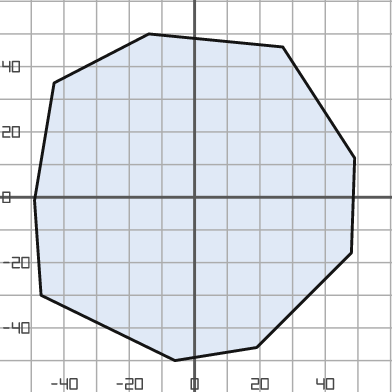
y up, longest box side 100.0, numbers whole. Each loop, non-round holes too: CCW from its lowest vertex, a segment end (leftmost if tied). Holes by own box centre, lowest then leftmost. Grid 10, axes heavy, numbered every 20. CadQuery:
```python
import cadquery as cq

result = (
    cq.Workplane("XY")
    .moveTo(-6.0, -50.0)
    .lineTo(19.0, -46.0)
    .lineTo(48.0, -17.0)
    .lineTo(49.0, 12.0)
    .lineTo(27.0, 46.0)
    .lineTo(-14.0, 50.0)
    .lineTo(-43.0, 35.0)
    .lineTo(-49.0, -1.0)
    .lineTo(-47.0, -30.0)
    .close()
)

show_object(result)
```